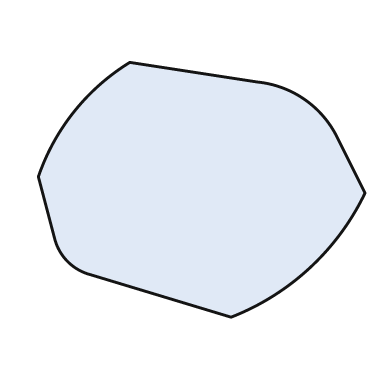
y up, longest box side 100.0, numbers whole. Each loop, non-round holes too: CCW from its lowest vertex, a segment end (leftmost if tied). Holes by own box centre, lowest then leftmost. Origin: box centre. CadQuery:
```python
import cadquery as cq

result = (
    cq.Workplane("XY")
    .moveTo(9.0, -39.0)
    .threePointArc((33.0, -24.0), (50.0, -1.0))
    .lineTo(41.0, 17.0)
    .threePointArc((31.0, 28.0), (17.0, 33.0))
    .lineTo(-22.0, 39.0)
    .threePointArc((-39.0, 24.0), (-50.0, 4.0))
    .lineTo(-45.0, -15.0)
    .threePointArc((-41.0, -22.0), (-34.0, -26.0))
    .close()
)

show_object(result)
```